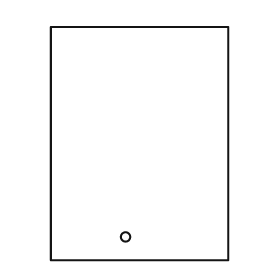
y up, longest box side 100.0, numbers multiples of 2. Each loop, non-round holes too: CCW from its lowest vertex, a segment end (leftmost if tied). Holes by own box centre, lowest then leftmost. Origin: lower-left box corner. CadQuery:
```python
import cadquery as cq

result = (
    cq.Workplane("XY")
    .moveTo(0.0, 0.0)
    .lineTo(76.0, 0.0)
    .lineTo(76.0, 100.0)
    .lineTo(0.0, 100.0)
    .close()
    .moveTo(32.0, 10.0)
    .circle(2.0)
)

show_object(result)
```